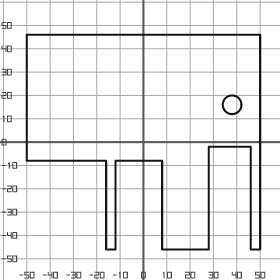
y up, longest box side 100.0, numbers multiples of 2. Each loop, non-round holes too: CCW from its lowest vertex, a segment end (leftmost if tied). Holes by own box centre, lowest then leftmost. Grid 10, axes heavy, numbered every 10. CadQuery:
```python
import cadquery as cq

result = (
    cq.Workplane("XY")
    .moveTo(-16.0, -46.0)
    .lineTo(-12.0, -46.0)
    .lineTo(-12.0, -8.0)
    .lineTo(8.0, -8.0)
    .lineTo(8.0, -46.0)
    .lineTo(28.0, -46.0)
    .lineTo(28.0, -2.0)
    .lineTo(46.0, -2.0)
    .lineTo(46.0, -46.0)
    .lineTo(50.0, -46.0)
    .lineTo(50.0, 46.0)
    .lineTo(-50.0, 46.0)
    .lineTo(-50.0, -8.0)
    .lineTo(-16.0, -8.0)
    .close()
    .moveTo(38.0, 16.0)
    .circle(4.0)
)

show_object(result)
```